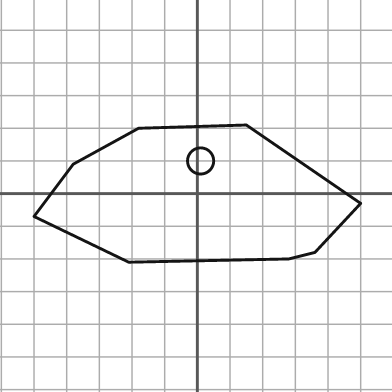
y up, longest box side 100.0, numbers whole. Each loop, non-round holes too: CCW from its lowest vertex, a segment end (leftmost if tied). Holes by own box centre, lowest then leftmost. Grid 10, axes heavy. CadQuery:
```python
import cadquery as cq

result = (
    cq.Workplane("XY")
    .moveTo(-21.0, -21.0)
    .lineTo(28.0, -20.0)
    .lineTo(36.0, -18.0)
    .lineTo(50.0, -3.0)
    .lineTo(15.0, 21.0)
    .lineTo(-18.0, 20.0)
    .lineTo(-38.0, 9.0)
    .lineTo(-50.0, -7.0)
    .close()
    .moveTo(1.0, 10.0)
    .circle(4.0)
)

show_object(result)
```